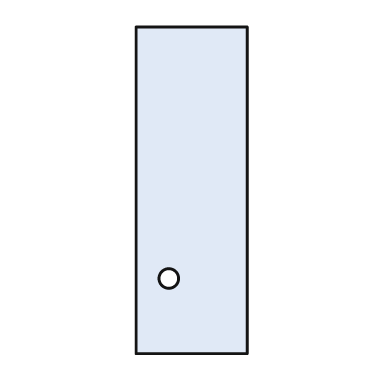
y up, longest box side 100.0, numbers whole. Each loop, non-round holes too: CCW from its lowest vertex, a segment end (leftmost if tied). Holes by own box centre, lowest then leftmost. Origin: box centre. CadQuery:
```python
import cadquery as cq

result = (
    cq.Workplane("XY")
    .moveTo(-17.0, -50.0)
    .lineTo(17.0, -50.0)
    .lineTo(17.0, 50.0)
    .lineTo(-17.0, 50.0)
    .close()
    .moveTo(-7.0, -27.0)
    .circle(3.0)
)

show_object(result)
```